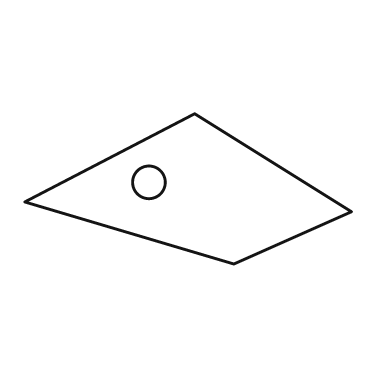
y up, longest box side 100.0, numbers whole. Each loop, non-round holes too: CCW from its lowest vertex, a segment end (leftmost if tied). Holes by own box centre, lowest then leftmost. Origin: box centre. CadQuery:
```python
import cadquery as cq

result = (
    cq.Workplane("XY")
    .moveTo(14.0, -23.0)
    .lineTo(50.0, -7.0)
    .lineTo(2.0, 23.0)
    .lineTo(-50.0, -4.0)
    .close()
    .moveTo(-12.0, 2.0)
    .circle(5.0)
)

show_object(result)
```